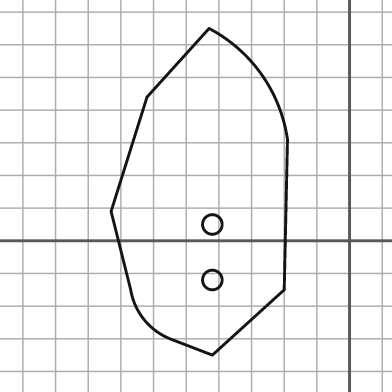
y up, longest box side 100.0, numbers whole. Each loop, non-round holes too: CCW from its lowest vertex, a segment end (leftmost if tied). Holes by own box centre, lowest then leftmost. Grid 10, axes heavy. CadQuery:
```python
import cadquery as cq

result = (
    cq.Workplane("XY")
    .moveTo(-42.0, -35.0)
    .lineTo(-20.0, -15.0)
    .lineTo(-19.0, 31.0)
    .threePointArc((-27.0, 51.0), (-43.0, 65.0))
    .lineTo(-62.0, 44.0)
    .lineTo(-73.0, 9.0)
    .lineTo(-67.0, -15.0)
    .threePointArc((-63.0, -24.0), (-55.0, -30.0))
    .close()
    .moveTo(-42.0, -12.0)
    .circle(3.0)
    .moveTo(-42.0, 5.0)
    .circle(3.0)
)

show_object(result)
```